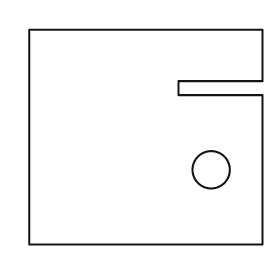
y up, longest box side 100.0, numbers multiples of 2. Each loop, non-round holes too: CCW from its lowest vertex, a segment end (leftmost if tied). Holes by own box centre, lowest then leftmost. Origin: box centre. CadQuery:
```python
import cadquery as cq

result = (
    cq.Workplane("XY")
    .moveTo(-50.0, -46.0)
    .lineTo(50.0, -46.0)
    .lineTo(50.0, 18.0)
    .lineTo(14.0, 18.0)
    .lineTo(14.0, 24.0)
    .lineTo(50.0, 24.0)
    .lineTo(50.0, 46.0)
    .lineTo(-50.0, 46.0)
    .close()
    .moveTo(28.0, -14.0)
    .circle(8.0)
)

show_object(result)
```